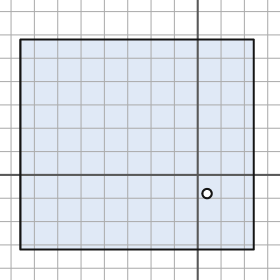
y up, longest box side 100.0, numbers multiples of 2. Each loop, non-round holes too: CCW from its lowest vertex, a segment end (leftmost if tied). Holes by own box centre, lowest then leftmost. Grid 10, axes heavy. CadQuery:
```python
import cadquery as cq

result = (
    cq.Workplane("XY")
    .moveTo(-76.0, -32.0)
    .lineTo(24.0, -32.0)
    .lineTo(24.0, 58.0)
    .lineTo(-76.0, 58.0)
    .close()
    .moveTo(4.0, -8.0)
    .circle(2.0)
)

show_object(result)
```